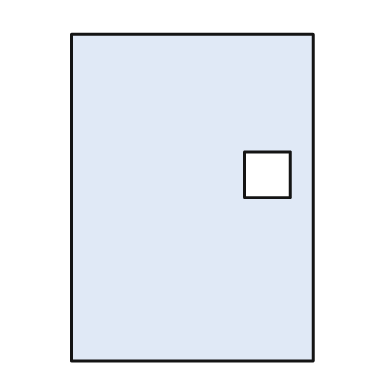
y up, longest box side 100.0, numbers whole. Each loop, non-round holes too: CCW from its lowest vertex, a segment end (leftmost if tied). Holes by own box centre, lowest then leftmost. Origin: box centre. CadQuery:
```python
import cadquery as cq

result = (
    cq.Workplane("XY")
    .moveTo(-37.0, -50.0)
    .lineTo(37.0, -50.0)
    .lineTo(37.0, 50.0)
    .lineTo(-37.0, 50.0)
    .close()
    .moveTo(16.0, 0.0)
    .lineTo(30.0, 0.0)
    .lineTo(30.0, 14.0)
    .lineTo(16.0, 14.0)
    .close()
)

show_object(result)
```